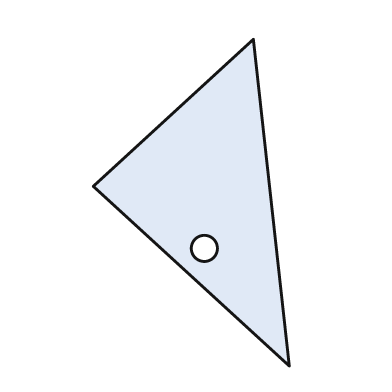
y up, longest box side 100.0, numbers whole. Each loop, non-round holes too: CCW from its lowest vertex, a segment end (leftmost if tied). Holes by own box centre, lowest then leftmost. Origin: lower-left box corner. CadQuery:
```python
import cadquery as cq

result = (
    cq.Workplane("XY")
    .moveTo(60.0, 0.0)
    .lineTo(49.0, 100.0)
    .lineTo(0.0, 55.0)
    .close()
    .moveTo(34.0, 36.0)
    .circle(4.0)
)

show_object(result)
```